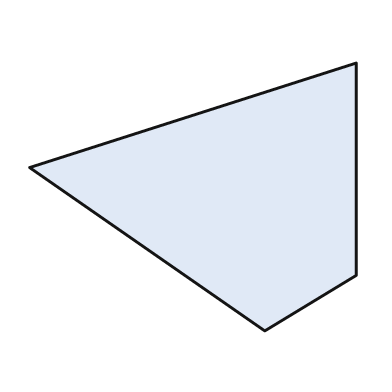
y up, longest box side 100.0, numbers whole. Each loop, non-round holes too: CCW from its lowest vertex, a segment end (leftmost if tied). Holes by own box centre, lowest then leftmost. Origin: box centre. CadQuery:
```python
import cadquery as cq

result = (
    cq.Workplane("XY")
    .moveTo(22.0, -41.0)
    .lineTo(50.0, -24.0)
    .lineTo(50.0, 41.0)
    .lineTo(-50.0, 9.0)
    .close()
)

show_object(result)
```